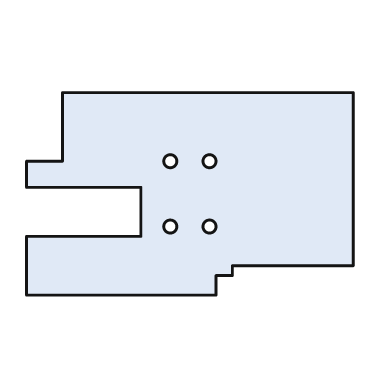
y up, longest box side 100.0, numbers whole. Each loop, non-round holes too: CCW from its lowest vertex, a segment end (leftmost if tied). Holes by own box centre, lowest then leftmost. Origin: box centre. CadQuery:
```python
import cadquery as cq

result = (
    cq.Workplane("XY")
    .moveTo(-50.0, -31.0)
    .lineTo(8.0, -31.0)
    .lineTo(8.0, -25.0)
    .lineTo(13.0, -25.0)
    .lineTo(13.0, -22.0)
    .lineTo(50.0, -22.0)
    .lineTo(50.0, 31.0)
    .lineTo(-39.0, 31.0)
    .lineTo(-39.0, 10.0)
    .lineTo(-50.0, 10.0)
    .lineTo(-50.0, 2.0)
    .lineTo(-15.0, 2.0)
    .lineTo(-15.0, -13.0)
    .lineTo(-50.0, -13.0)
    .close()
    .moveTo(-6.0, -10.0)
    .circle(2.0)
    .moveTo(6.0, -10.0)
    .circle(2.0)
    .moveTo(-6.0, 10.0)
    .circle(2.0)
    .moveTo(6.0, 10.0)
    .circle(2.0)
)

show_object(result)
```